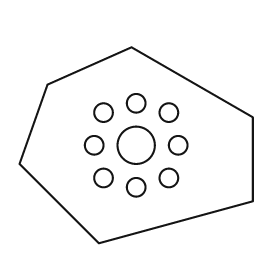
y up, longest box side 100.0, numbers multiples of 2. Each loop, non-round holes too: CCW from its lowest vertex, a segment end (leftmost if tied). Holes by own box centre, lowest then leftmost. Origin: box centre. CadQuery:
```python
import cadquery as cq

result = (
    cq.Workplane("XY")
    .moveTo(-16.0, -42.0)
    .lineTo(50.0, -24.0)
    .lineTo(50.0, 12.0)
    .lineTo(-2.0, 42.0)
    .lineTo(-38.0, 26.0)
    .lineTo(-50.0, -8.0)
    .close()
    .moveTo(0.0, -18.0)
    .circle(4.0)
    .moveTo(-14.0, -14.0)
    .circle(4.0)
    .moveTo(14.0, -14.0)
    .circle(4.0)
    .moveTo(-18.0, 0.0)
    .circle(4.0)
    .moveTo(0.0, 0.0)
    .circle(8.0)
    .moveTo(18.0, 0.0)
    .circle(4.0)
    .moveTo(-14.0, 14.0)
    .circle(4.0)
    .moveTo(14.0, 14.0)
    .circle(4.0)
    .moveTo(0.0, 18.0)
    .circle(4.0)
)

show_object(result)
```